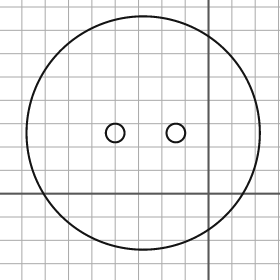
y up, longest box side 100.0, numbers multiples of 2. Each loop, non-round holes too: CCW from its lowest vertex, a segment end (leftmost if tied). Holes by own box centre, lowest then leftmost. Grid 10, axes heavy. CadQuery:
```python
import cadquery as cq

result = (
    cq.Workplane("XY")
    .moveTo(-28.0, 26.0)
    .circle(50.0)
    .moveTo(-40.0, 26.0)
    .circle(4.0)
    .moveTo(-14.0, 26.0)
    .circle(4.0)
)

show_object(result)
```